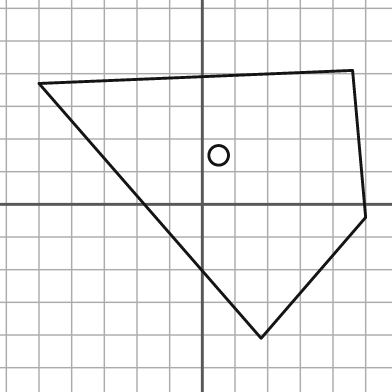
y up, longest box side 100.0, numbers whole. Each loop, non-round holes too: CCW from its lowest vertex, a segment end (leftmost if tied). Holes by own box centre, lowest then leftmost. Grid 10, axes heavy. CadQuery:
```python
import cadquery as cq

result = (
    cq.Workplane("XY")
    .moveTo(18.0, -41.0)
    .lineTo(50.0, -4.0)
    .lineTo(46.0, 41.0)
    .lineTo(-50.0, 37.0)
    .close()
    .moveTo(5.0, 15.0)
    .circle(3.0)
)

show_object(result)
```